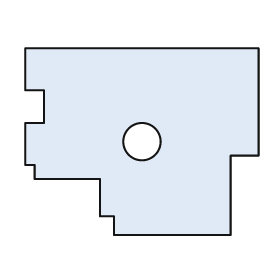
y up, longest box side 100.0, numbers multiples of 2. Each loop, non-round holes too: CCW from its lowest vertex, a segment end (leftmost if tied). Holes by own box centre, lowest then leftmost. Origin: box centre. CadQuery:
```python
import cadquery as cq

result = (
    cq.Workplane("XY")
    .moveTo(-12.0, -40.0)
    .lineTo(38.0, -40.0)
    .lineTo(38.0, -6.0)
    .lineTo(50.0, -6.0)
    .lineTo(50.0, 40.0)
    .lineTo(-50.0, 40.0)
    .lineTo(-50.0, 22.0)
    .lineTo(-42.0, 22.0)
    .lineTo(-42.0, 8.0)
    .lineTo(-50.0, 8.0)
    .lineTo(-50.0, -10.0)
    .lineTo(-46.0, -10.0)
    .lineTo(-46.0, -16.0)
    .lineTo(-18.0, -16.0)
    .lineTo(-18.0, -32.0)
    .lineTo(-12.0, -32.0)
    .close()
    .moveTo(0.0, 0.0)
    .circle(8.0)
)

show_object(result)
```